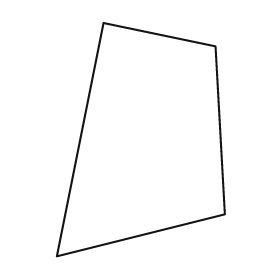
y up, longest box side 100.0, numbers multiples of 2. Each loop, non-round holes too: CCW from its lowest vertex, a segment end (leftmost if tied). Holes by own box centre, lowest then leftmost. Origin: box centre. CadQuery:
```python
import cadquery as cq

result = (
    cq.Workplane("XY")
    .moveTo(-36.0, -50.0)
    .lineTo(36.0, -32.0)
    .lineTo(32.0, 40.0)
    .lineTo(-16.0, 50.0)
    .close()
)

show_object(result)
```